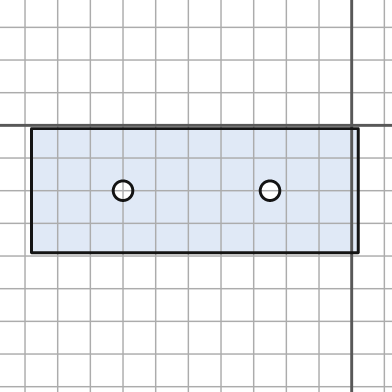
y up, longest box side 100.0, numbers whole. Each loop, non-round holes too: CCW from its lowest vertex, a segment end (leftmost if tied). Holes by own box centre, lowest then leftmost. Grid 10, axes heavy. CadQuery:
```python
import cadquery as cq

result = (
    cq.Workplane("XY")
    .moveTo(-98.0, -39.0)
    .lineTo(2.0, -39.0)
    .lineTo(2.0, -1.0)
    .lineTo(-98.0, -1.0)
    .close()
    .moveTo(-70.0, -20.0)
    .circle(3.0)
    .moveTo(-25.0, -20.0)
    .circle(3.0)
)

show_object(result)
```